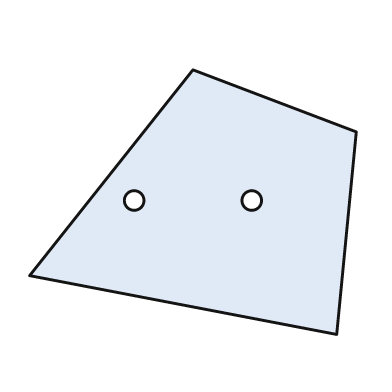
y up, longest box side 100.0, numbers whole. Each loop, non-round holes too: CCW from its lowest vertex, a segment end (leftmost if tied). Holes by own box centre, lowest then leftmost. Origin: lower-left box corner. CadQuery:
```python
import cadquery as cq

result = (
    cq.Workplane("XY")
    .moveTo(94.0, 0.0)
    .lineTo(100.0, 62.0)
    .lineTo(50.0, 81.0)
    .lineTo(0.0, 18.0)
    .close()
    .moveTo(32.0, 41.0)
    .circle(3.0)
    .moveTo(68.0, 41.0)
    .circle(3.0)
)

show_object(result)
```